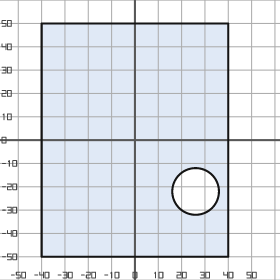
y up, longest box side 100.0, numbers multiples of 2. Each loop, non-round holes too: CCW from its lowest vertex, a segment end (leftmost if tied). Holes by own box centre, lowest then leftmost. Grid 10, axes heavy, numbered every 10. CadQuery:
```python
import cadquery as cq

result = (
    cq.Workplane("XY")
    .moveTo(-40.0, -50.0)
    .lineTo(40.0, -50.0)
    .lineTo(40.0, 50.0)
    .lineTo(-40.0, 50.0)
    .close()
    .moveTo(26.0, -22.0)
    .circle(10.0)
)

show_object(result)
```